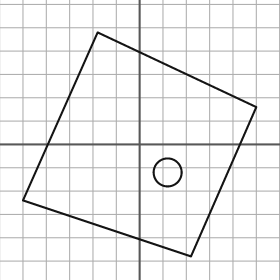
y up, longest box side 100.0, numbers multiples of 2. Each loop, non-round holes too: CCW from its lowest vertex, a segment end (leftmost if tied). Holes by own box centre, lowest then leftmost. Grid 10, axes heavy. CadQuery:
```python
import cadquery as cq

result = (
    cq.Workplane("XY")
    .moveTo(22.0, -48.0)
    .lineTo(50.0, 16.0)
    .lineTo(-18.0, 48.0)
    .lineTo(-50.0, -24.0)
    .close()
    .moveTo(12.0, -12.0)
    .circle(6.0)
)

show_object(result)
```